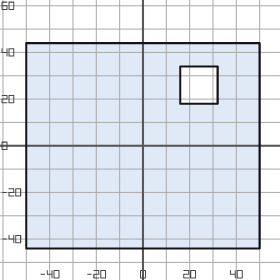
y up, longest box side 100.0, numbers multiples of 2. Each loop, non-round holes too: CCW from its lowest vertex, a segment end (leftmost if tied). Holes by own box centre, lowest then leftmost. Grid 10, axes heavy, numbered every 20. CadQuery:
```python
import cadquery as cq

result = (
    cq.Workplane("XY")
    .moveTo(-50.0, -44.0)
    .lineTo(50.0, -44.0)
    .lineTo(50.0, 44.0)
    .lineTo(-50.0, 44.0)
    .close()
    .moveTo(16.0, 18.0)
    .lineTo(32.0, 18.0)
    .lineTo(32.0, 34.0)
    .lineTo(16.0, 34.0)
    .close()
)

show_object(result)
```